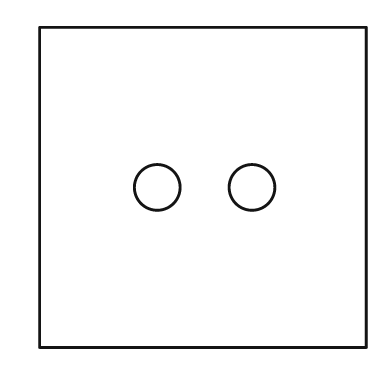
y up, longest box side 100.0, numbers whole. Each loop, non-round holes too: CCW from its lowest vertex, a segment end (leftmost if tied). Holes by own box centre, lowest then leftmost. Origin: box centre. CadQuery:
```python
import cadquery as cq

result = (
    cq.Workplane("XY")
    .moveTo(-50.0, -49.0)
    .lineTo(50.0, -49.0)
    .lineTo(50.0, 49.0)
    .lineTo(-50.0, 49.0)
    .close()
    .moveTo(-14.0, 0.0)
    .circle(7.0)
    .moveTo(15.0, 0.0)
    .circle(7.0)
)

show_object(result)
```